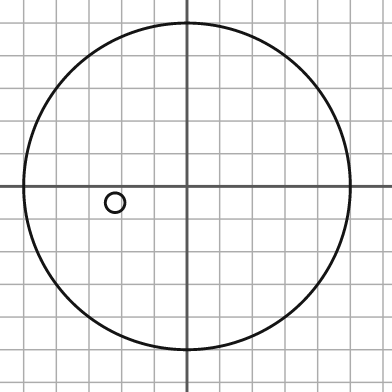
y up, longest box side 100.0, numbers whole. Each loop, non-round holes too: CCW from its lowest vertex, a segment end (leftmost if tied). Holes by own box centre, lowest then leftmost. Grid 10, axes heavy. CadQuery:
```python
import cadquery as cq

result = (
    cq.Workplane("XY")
    .moveTo(0.0, 0.0)
    .circle(50.0)
    .moveTo(-22.0, -5.0)
    .circle(3.0)
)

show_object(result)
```